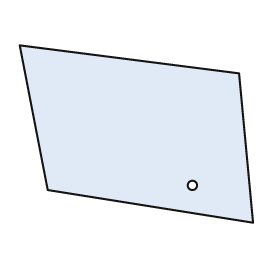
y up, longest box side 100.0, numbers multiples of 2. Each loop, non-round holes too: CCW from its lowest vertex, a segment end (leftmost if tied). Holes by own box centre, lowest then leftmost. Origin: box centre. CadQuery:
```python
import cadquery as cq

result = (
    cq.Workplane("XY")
    .moveTo(50.0, -38.0)
    .lineTo(44.0, 26.0)
    .lineTo(-50.0, 38.0)
    .lineTo(-38.0, -24.0)
    .close()
    .moveTo(24.0, -22.0)
    .circle(2.0)
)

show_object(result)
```